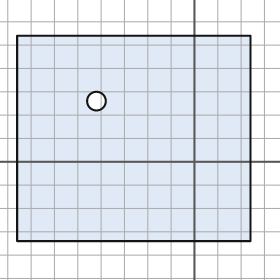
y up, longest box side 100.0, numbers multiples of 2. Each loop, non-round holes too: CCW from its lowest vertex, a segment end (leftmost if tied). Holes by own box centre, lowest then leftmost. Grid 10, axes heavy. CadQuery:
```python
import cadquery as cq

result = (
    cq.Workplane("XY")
    .moveTo(-76.0, -34.0)
    .lineTo(24.0, -34.0)
    .lineTo(24.0, 54.0)
    .lineTo(-76.0, 54.0)
    .close()
    .moveTo(-42.0, 26.0)
    .circle(4.0)
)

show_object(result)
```